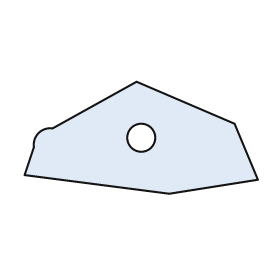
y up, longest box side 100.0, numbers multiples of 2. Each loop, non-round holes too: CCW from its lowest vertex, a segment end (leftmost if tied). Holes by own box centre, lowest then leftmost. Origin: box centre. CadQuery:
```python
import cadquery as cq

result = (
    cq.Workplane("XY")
    .moveTo(12.0, -24.0)
    .lineTo(50.0, -18.0)
    .lineTo(40.0, 6.0)
    .lineTo(-2.0, 24.0)
    .lineTo(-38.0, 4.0)
    .threePointArc((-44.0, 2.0), (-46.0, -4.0))
    .lineTo(-50.0, -16.0)
    .close()
    .moveTo(0.0, 0.0)
    .circle(6.0)
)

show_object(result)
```